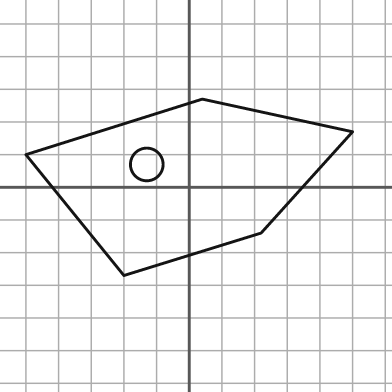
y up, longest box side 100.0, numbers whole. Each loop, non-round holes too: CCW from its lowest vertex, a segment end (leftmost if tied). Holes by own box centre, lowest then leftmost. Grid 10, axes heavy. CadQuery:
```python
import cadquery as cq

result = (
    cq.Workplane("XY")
    .moveTo(-20.0, -27.0)
    .lineTo(22.0, -14.0)
    .lineTo(50.0, 17.0)
    .lineTo(4.0, 27.0)
    .lineTo(-50.0, 10.0)
    .close()
    .moveTo(-13.0, 7.0)
    .circle(5.0)
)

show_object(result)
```